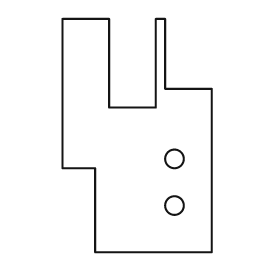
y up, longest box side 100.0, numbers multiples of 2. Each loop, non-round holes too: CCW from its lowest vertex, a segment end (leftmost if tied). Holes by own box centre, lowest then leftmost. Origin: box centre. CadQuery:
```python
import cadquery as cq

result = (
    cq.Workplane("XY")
    .moveTo(-18.0, -50.0)
    .lineTo(32.0, -50.0)
    .lineTo(32.0, 20.0)
    .lineTo(12.0, 20.0)
    .lineTo(12.0, 50.0)
    .lineTo(8.0, 50.0)
    .lineTo(8.0, 12.0)
    .lineTo(-12.0, 12.0)
    .lineTo(-12.0, 50.0)
    .lineTo(-32.0, 50.0)
    .lineTo(-32.0, -14.0)
    .lineTo(-18.0, -14.0)
    .close()
    .moveTo(16.0, -30.0)
    .circle(4.0)
    .moveTo(16.0, -10.0)
    .circle(4.0)
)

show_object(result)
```